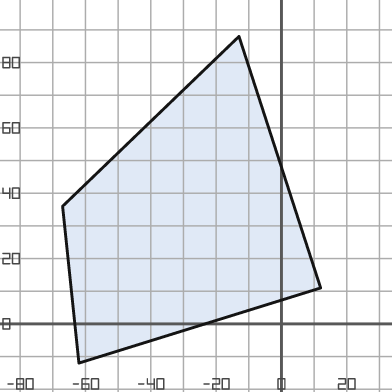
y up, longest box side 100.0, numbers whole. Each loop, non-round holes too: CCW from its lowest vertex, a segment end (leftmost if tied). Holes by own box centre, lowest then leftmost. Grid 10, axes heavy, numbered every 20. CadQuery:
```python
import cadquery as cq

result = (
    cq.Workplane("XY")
    .moveTo(-62.0, -12.0)
    .lineTo(12.0, 11.0)
    .lineTo(-13.0, 88.0)
    .lineTo(-67.0, 36.0)
    .close()
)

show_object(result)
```